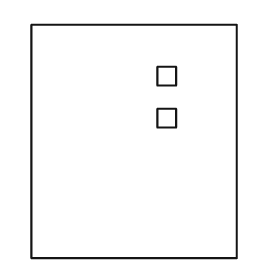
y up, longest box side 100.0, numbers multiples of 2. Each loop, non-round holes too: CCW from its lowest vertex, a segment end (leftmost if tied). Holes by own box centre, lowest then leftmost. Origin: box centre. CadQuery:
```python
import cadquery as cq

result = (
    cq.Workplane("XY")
    .moveTo(-44.0, -50.0)
    .lineTo(44.0, -50.0)
    .lineTo(44.0, 50.0)
    .lineTo(-44.0, 50.0)
    .close()
    .moveTo(10.0, 6.0)
    .lineTo(18.0, 6.0)
    .lineTo(18.0, 14.0)
    .lineTo(10.0, 14.0)
    .close()
    .moveTo(10.0, 24.0)
    .lineTo(18.0, 24.0)
    .lineTo(18.0, 32.0)
    .lineTo(10.0, 32.0)
    .close()
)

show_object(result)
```